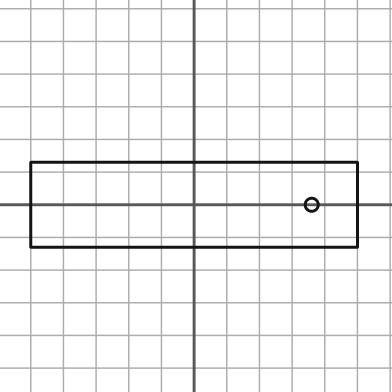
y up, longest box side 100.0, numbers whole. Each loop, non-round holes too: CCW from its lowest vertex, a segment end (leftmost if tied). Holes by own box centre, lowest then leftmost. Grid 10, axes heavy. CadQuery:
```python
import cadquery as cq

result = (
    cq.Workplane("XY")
    .moveTo(-50.0, -13.0)
    .lineTo(50.0, -13.0)
    .lineTo(50.0, 13.0)
    .lineTo(-50.0, 13.0)
    .close()
    .moveTo(36.0, 0.0)
    .circle(2.0)
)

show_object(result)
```